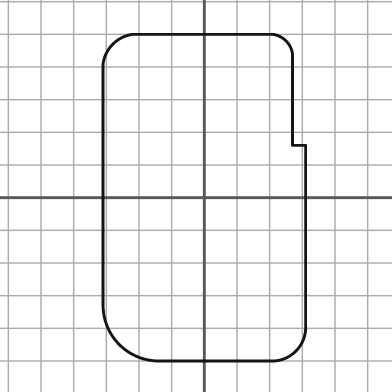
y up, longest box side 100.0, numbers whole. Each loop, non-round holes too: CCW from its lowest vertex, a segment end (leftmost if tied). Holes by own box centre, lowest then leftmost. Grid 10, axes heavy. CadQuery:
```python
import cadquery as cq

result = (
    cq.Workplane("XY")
    .moveTo(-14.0, -50.0)
    .lineTo(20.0, -50.0)
    .threePointArc((28.0, -47.0), (31.0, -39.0))
    .lineTo(31.0, 16.0)
    .lineTo(27.0, 16.0)
    .lineTo(27.0, 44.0)
    .threePointArc((25.0, 48.0), (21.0, 50.0))
    .lineTo(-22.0, 50.0)
    .threePointArc((-28.0, 47.0), (-31.0, 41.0))
    .lineTo(-31.0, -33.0)
    .threePointArc((-26.0, -45.0), (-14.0, -50.0))
    .close()
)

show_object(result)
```